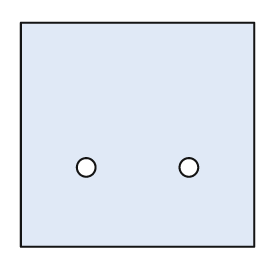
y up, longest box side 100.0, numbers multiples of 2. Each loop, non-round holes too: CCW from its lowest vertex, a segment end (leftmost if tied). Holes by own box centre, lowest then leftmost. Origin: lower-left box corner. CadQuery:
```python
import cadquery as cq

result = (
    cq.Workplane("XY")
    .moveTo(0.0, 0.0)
    .lineTo(100.0, 0.0)
    .lineTo(100.0, 96.0)
    .lineTo(0.0, 96.0)
    .close()
    .moveTo(28.0, 34.0)
    .circle(4.0)
    .moveTo(72.0, 34.0)
    .circle(4.0)
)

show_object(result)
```